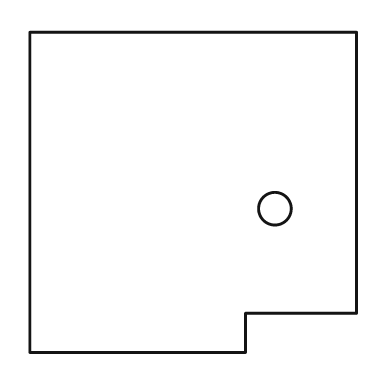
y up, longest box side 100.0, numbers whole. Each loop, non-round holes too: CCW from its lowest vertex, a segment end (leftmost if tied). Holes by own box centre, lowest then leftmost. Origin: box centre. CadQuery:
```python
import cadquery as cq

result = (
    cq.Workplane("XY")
    .moveTo(-50.0, -49.0)
    .lineTo(16.0, -49.0)
    .lineTo(16.0, -37.0)
    .lineTo(50.0, -37.0)
    .lineTo(50.0, 49.0)
    .lineTo(-50.0, 49.0)
    .close()
    .moveTo(25.0, -5.0)
    .circle(5.0)
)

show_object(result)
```